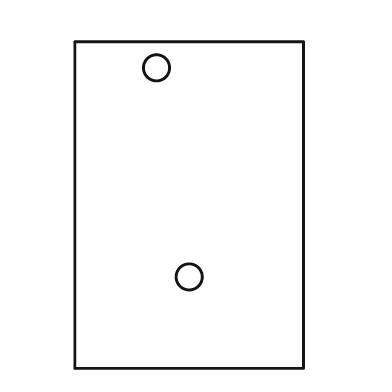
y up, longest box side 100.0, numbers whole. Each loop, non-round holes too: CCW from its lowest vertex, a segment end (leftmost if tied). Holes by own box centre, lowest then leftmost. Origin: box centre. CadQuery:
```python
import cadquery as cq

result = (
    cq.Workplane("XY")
    .moveTo(-35.0, -50.0)
    .lineTo(35.0, -50.0)
    .lineTo(35.0, 50.0)
    .lineTo(-35.0, 50.0)
    .close()
    .moveTo(0.0, -22.0)
    .circle(4.0)
    .moveTo(-10.0, 42.0)
    .circle(4.0)
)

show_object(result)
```